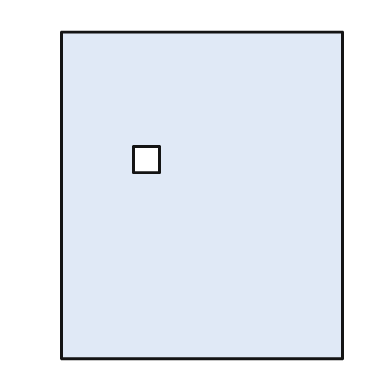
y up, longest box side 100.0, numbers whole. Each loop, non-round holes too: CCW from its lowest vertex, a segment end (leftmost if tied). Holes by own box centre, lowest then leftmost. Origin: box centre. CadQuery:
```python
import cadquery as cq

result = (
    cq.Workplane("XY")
    .moveTo(-43.0, -50.0)
    .lineTo(43.0, -50.0)
    .lineTo(43.0, 50.0)
    .lineTo(-43.0, 50.0)
    .close()
    .moveTo(-21.0, 7.0)
    .lineTo(-13.0, 7.0)
    .lineTo(-13.0, 15.0)
    .lineTo(-21.0, 15.0)
    .close()
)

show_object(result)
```